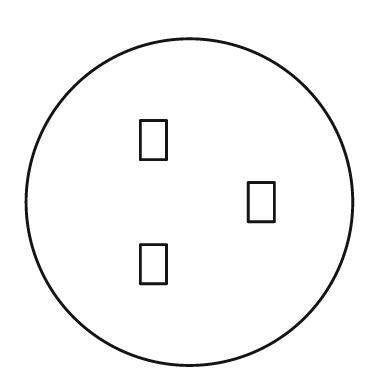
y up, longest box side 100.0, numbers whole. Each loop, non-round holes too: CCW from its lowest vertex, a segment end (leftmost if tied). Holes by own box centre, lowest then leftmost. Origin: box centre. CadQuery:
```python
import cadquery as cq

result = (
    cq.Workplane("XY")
    .moveTo(0.0, 0.0)
    .circle(50.0)
    .moveTo(-15.0, -25.0)
    .lineTo(-7.0, -25.0)
    .lineTo(-7.0, -13.0)
    .lineTo(-15.0, -13.0)
    .close()
    .moveTo(18.0, -6.0)
    .lineTo(26.0, -6.0)
    .lineTo(26.0, 6.0)
    .lineTo(18.0, 6.0)
    .close()
    .moveTo(-15.0, 13.0)
    .lineTo(-7.0, 13.0)
    .lineTo(-7.0, 25.0)
    .lineTo(-15.0, 25.0)
    .close()
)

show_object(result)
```